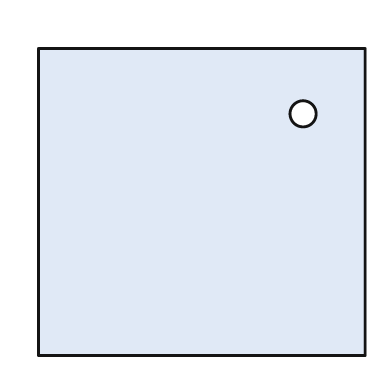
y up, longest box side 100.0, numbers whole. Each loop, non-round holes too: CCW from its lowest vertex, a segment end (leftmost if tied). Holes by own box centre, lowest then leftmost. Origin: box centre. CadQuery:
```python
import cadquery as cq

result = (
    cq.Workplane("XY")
    .moveTo(-50.0, -47.0)
    .lineTo(50.0, -47.0)
    .lineTo(50.0, 47.0)
    .lineTo(-50.0, 47.0)
    .close()
    .moveTo(31.0, 27.0)
    .circle(4.0)
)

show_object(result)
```